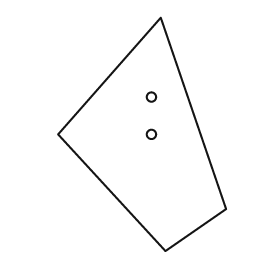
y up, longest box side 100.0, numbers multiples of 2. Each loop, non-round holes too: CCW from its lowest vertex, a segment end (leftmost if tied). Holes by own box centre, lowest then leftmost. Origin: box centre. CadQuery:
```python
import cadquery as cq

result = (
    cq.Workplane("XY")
    .moveTo(10.0, -50.0)
    .lineTo(36.0, -32.0)
    .lineTo(8.0, 50.0)
    .lineTo(-36.0, 0.0)
    .close()
    .moveTo(4.0, 0.0)
    .circle(2.0)
    .moveTo(4.0, 16.0)
    .circle(2.0)
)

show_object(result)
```